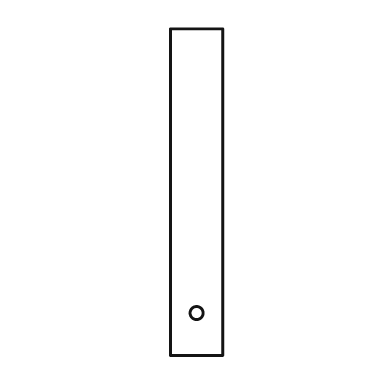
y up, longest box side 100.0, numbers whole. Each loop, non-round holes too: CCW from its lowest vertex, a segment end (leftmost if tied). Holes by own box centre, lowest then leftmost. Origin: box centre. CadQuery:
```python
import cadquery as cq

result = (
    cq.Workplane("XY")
    .moveTo(-8.0, -50.0)
    .lineTo(8.0, -50.0)
    .lineTo(8.0, 50.0)
    .lineTo(-8.0, 50.0)
    .close()
    .moveTo(0.0, -37.0)
    .circle(2.0)
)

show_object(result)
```